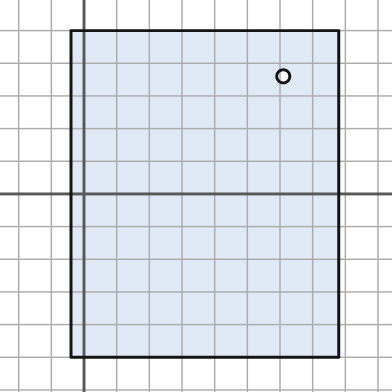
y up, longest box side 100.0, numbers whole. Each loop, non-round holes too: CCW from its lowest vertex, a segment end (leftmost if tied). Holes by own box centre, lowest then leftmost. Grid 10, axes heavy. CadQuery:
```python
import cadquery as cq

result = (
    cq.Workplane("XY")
    .moveTo(-4.0, -50.0)
    .lineTo(78.0, -50.0)
    .lineTo(78.0, 50.0)
    .lineTo(-4.0, 50.0)
    .close()
    .moveTo(61.0, 36.0)
    .circle(2.0)
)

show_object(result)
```